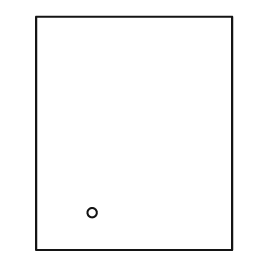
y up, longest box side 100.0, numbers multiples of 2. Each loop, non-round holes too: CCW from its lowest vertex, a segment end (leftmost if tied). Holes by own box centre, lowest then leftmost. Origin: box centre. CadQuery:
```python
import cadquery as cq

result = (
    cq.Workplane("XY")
    .moveTo(-42.0, -50.0)
    .lineTo(42.0, -50.0)
    .lineTo(42.0, 50.0)
    .lineTo(-42.0, 50.0)
    .close()
    .moveTo(-18.0, -34.0)
    .circle(2.0)
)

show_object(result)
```